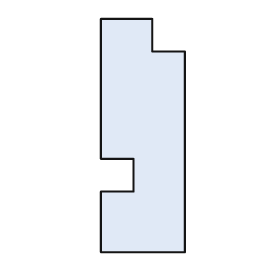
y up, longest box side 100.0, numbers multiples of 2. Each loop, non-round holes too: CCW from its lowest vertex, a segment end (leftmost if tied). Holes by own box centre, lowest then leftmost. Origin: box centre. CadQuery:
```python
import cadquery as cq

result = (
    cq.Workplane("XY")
    .moveTo(-18.0, -50.0)
    .lineTo(18.0, -50.0)
    .lineTo(18.0, 36.0)
    .lineTo(4.0, 36.0)
    .lineTo(4.0, 50.0)
    .lineTo(-18.0, 50.0)
    .lineTo(-18.0, -10.0)
    .lineTo(-4.0, -10.0)
    .lineTo(-4.0, -24.0)
    .lineTo(-18.0, -24.0)
    .close()
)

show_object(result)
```